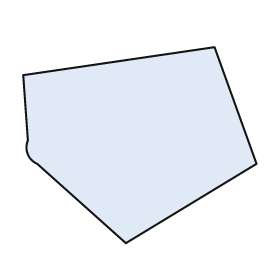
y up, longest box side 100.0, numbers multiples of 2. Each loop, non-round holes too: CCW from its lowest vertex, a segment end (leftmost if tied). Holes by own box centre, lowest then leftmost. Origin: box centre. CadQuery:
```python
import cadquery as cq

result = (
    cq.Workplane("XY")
    .moveTo(-6.0, -42.0)
    .lineTo(50.0, -8.0)
    .lineTo(32.0, 42.0)
    .lineTo(-50.0, 30.0)
    .lineTo(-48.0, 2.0)
    .threePointArc((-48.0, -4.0), (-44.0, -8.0))
    .close()
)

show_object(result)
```